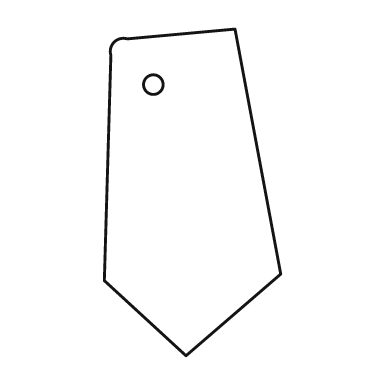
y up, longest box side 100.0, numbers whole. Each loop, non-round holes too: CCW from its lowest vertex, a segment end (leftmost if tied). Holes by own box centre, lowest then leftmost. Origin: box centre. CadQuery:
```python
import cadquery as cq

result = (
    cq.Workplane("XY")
    .moveTo(-2.0, -50.0)
    .lineTo(27.0, -25.0)
    .lineTo(13.0, 50.0)
    .lineTo(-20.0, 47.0)
    .threePointArc((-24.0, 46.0), (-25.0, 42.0))
    .lineTo(-27.0, -27.0)
    .close()
    .moveTo(-12.0, 33.0)
    .circle(3.0)
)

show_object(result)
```